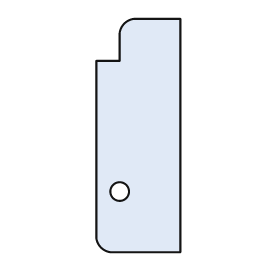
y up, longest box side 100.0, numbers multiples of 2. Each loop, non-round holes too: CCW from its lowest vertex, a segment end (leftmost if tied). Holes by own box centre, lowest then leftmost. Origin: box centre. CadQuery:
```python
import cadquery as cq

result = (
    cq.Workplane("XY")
    .moveTo(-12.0, -50.0)
    .lineTo(18.0, -50.0)
    .lineTo(18.0, 50.0)
    .lineTo(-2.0, 50.0)
    .threePointArc((-6.0, 48.0), (-8.0, 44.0))
    .lineTo(-8.0, 32.0)
    .lineTo(-18.0, 32.0)
    .lineTo(-18.0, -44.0)
    .threePointArc((-16.0, -48.0), (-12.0, -50.0))
    .close()
    .moveTo(-8.0, -24.0)
    .circle(4.0)
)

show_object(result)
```